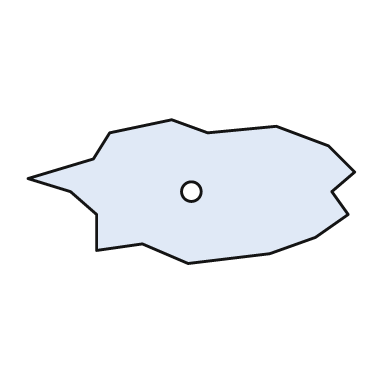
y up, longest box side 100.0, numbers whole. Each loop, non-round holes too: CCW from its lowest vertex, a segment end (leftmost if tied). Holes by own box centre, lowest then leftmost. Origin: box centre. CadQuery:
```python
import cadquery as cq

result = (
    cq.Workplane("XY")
    .moveTo(-1.0, -22.0)
    .lineTo(24.0, -19.0)
    .lineTo(38.0, -14.0)
    .lineTo(48.0, -7.0)
    .lineTo(43.0, 0.0)
    .lineTo(50.0, 6.0)
    .lineTo(42.0, 14.0)
    .lineTo(26.0, 20.0)
    .lineTo(5.0, 18.0)
    .lineTo(-6.0, 22.0)
    .lineTo(-25.0, 18.0)
    .lineTo(-30.0, 10.0)
    .lineTo(-50.0, 4.0)
    .lineTo(-37.0, 0.0)
    .lineTo(-29.0, -7.0)
    .lineTo(-29.0, -18.0)
    .lineTo(-15.0, -16.0)
    .close()
    .moveTo(0.0, 0.0)
    .circle(3.0)
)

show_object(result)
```